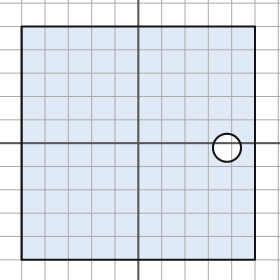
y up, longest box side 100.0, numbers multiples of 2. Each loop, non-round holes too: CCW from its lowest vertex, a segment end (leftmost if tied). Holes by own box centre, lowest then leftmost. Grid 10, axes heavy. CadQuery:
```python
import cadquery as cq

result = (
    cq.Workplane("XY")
    .moveTo(-50.0, -50.0)
    .lineTo(50.0, -50.0)
    .lineTo(50.0, 50.0)
    .lineTo(-50.0, 50.0)
    .close()
    .moveTo(38.0, -2.0)
    .circle(6.0)
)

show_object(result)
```